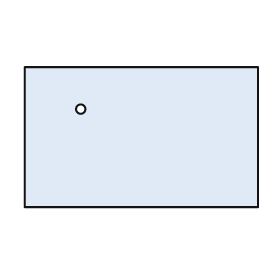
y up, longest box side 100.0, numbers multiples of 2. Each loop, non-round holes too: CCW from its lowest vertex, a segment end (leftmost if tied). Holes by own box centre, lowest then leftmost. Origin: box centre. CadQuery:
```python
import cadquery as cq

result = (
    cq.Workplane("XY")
    .moveTo(-50.0, -30.0)
    .lineTo(50.0, -30.0)
    .lineTo(50.0, 30.0)
    .lineTo(-50.0, 30.0)
    .close()
    .moveTo(-26.0, 12.0)
    .circle(2.0)
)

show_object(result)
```